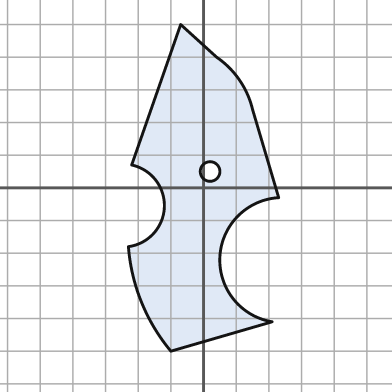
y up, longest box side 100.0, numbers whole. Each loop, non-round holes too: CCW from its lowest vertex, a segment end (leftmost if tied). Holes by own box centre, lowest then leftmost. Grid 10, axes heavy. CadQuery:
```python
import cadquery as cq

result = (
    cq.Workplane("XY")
    .moveTo(-10.0, -50.0)
    .lineTo(21.0, -41.0)
    .threePointArc((5.0, -21.0), (23.0, -3.0))
    .lineTo(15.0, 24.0)
    .threePointArc((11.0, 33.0), (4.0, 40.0))
    .lineTo(-7.0, 50.0)
    .lineTo(-22.0, 7.0)
    .threePointArc((-12.0, -6.0), (-23.0, -18.0))
    .threePointArc((-19.0, -35.0), (-10.0, -50.0))
    .close()
    .moveTo(2.0, 5.0)
    .circle(3.0)
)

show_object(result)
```